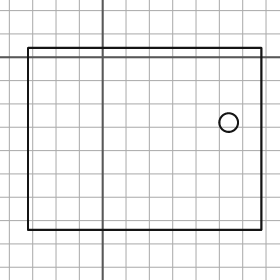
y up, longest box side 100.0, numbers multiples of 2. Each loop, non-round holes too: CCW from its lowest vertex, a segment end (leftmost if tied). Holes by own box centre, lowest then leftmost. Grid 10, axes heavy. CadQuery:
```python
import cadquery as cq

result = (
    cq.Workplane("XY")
    .moveTo(-32.0, -74.0)
    .lineTo(68.0, -74.0)
    .lineTo(68.0, 4.0)
    .lineTo(-32.0, 4.0)
    .close()
    .moveTo(54.0, -28.0)
    .circle(4.0)
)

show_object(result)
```